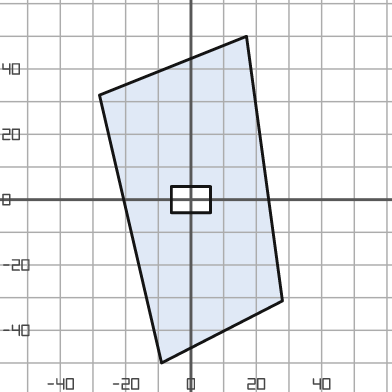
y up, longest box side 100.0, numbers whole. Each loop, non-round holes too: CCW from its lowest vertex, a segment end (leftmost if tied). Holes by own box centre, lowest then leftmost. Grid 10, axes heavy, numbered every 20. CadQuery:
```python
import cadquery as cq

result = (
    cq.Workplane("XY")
    .moveTo(-9.0, -50.0)
    .lineTo(28.0, -31.0)
    .lineTo(17.0, 50.0)
    .lineTo(-28.0, 32.0)
    .close()
    .moveTo(-6.0, -4.0)
    .lineTo(6.0, -4.0)
    .lineTo(6.0, 4.0)
    .lineTo(-6.0, 4.0)
    .close()
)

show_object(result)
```